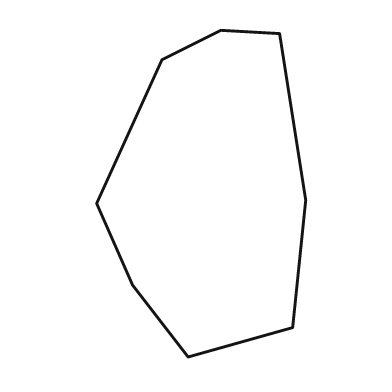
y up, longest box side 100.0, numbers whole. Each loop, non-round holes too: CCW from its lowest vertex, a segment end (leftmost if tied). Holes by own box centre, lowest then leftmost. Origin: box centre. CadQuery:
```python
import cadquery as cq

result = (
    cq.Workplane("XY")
    .moveTo(-4.0, -50.0)
    .lineTo(28.0, -41.0)
    .lineTo(32.0, -2.0)
    .lineTo(24.0, 49.0)
    .lineTo(6.0, 50.0)
    .lineTo(-12.0, 41.0)
    .lineTo(-32.0, -3.0)
    .lineTo(-21.0, -28.0)
    .close()
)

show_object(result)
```